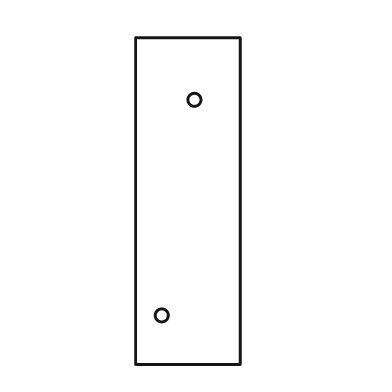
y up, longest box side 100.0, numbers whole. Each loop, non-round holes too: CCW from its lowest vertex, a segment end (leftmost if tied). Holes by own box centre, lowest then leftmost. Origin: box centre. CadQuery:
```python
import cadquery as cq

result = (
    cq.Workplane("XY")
    .moveTo(-16.0, -50.0)
    .lineTo(16.0, -50.0)
    .lineTo(16.0, 50.0)
    .lineTo(-16.0, 50.0)
    .close()
    .moveTo(-8.0, -35.0)
    .circle(2.0)
    .moveTo(2.0, 31.0)
    .circle(2.0)
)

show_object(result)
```